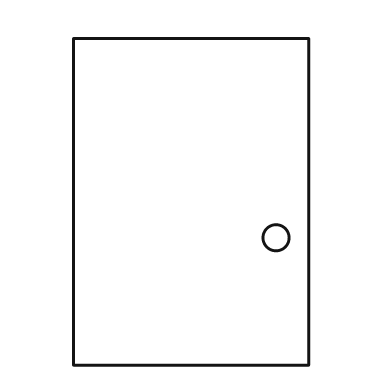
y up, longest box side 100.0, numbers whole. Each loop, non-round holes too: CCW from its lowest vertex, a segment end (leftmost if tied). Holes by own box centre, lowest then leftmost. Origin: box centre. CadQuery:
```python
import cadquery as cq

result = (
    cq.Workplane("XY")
    .moveTo(-36.0, -50.0)
    .lineTo(36.0, -50.0)
    .lineTo(36.0, 50.0)
    .lineTo(-36.0, 50.0)
    .close()
    .moveTo(26.0, -11.0)
    .circle(4.0)
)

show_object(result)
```